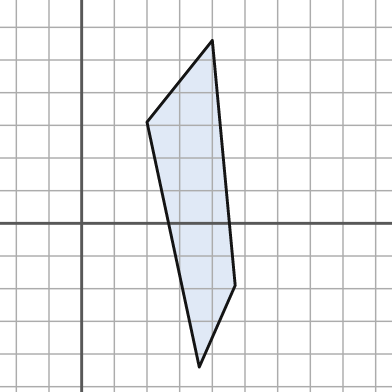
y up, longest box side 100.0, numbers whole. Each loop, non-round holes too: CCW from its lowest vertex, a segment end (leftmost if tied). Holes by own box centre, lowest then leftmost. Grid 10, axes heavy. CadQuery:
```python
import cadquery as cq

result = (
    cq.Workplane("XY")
    .moveTo(36.0, -44.0)
    .lineTo(47.0, -19.0)
    .lineTo(40.0, 56.0)
    .lineTo(20.0, 31.0)
    .close()
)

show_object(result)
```